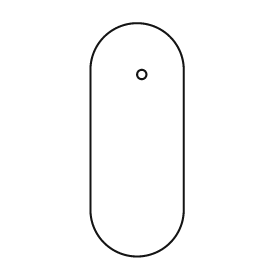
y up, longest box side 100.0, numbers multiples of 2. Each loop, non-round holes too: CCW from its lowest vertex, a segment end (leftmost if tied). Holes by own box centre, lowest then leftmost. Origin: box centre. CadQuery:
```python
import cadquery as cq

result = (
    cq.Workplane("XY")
    .moveTo(-20.0, -30.0)
    .threePointArc((0.0, -50.0), (20.0, -30.0))
    .lineTo(20.0, 30.0)
    .threePointArc((0.0, 50.0), (-20.0, 30.0))
    .close()
    .moveTo(2.0, 28.0)
    .circle(2.0)
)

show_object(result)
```